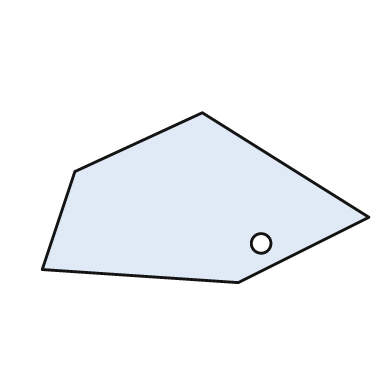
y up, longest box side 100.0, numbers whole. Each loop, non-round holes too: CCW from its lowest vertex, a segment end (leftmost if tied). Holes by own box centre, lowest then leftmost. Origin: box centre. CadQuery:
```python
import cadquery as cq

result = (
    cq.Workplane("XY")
    .moveTo(10.0, -26.0)
    .lineTo(50.0, -6.0)
    .lineTo(-1.0, 26.0)
    .lineTo(-40.0, 8.0)
    .lineTo(-50.0, -22.0)
    .close()
    .moveTo(17.0, -14.0)
    .circle(3.0)
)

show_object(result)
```